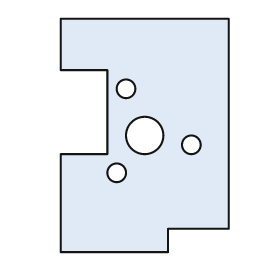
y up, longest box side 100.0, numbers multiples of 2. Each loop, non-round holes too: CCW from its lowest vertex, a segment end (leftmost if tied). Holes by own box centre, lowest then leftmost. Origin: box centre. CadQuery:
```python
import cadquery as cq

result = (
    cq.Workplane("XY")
    .moveTo(-36.0, -50.0)
    .lineTo(10.0, -50.0)
    .lineTo(10.0, -40.0)
    .lineTo(36.0, -40.0)
    .lineTo(36.0, 50.0)
    .lineTo(-36.0, 50.0)
    .lineTo(-36.0, 28.0)
    .lineTo(-16.0, 28.0)
    .lineTo(-16.0, -8.0)
    .lineTo(-36.0, -8.0)
    .close()
    .moveTo(-12.0, -16.0)
    .circle(4.0)
    .moveTo(20.0, -4.0)
    .circle(4.0)
    .moveTo(0.0, 0.0)
    .circle(8.0)
    .moveTo(-8.0, 20.0)
    .circle(4.0)
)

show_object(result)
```